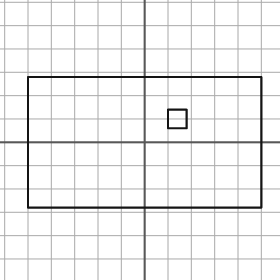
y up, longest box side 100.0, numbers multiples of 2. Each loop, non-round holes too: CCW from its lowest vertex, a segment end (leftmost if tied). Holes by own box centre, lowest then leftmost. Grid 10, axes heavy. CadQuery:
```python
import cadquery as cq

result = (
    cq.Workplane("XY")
    .moveTo(-50.0, -28.0)
    .lineTo(50.0, -28.0)
    .lineTo(50.0, 28.0)
    .lineTo(-50.0, 28.0)
    .close()
    .moveTo(10.0, 6.0)
    .lineTo(18.0, 6.0)
    .lineTo(18.0, 14.0)
    .lineTo(10.0, 14.0)
    .close()
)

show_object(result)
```